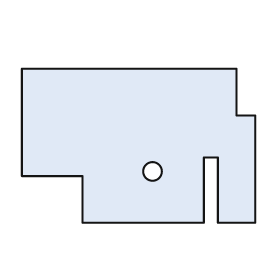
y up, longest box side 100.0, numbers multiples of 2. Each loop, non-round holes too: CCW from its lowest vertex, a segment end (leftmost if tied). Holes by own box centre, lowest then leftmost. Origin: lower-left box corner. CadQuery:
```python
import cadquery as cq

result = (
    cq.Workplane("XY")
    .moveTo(26.0, 0.0)
    .lineTo(78.0, 0.0)
    .lineTo(78.0, 28.0)
    .lineTo(84.0, 28.0)
    .lineTo(84.0, 0.0)
    .lineTo(100.0, 0.0)
    .lineTo(100.0, 46.0)
    .lineTo(92.0, 46.0)
    .lineTo(92.0, 66.0)
    .lineTo(0.0, 66.0)
    .lineTo(0.0, 20.0)
    .lineTo(26.0, 20.0)
    .close()
    .moveTo(56.0, 22.0)
    .circle(4.0)
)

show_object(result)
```